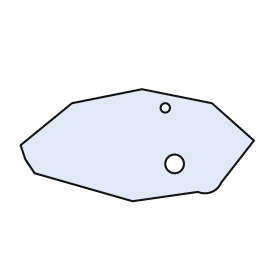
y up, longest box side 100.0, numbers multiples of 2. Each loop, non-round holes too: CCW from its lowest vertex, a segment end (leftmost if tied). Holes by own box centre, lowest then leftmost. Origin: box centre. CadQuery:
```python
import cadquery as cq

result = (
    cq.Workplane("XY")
    .moveTo(-2.0, -24.0)
    .lineTo(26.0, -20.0)
    .threePointArc((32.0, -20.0), (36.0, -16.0))
    .lineTo(50.0, 2.0)
    .lineTo(32.0, 18.0)
    .lineTo(2.0, 24.0)
    .lineTo(-28.0, 18.0)
    .lineTo(-50.0, 0.0)
    .lineTo(-48.0, -6.0)
    .lineTo(-44.0, -12.0)
    .close()
    .moveTo(16.0, -8.0)
    .circle(4.0)
    .moveTo(12.0, 16.0)
    .circle(2.0)
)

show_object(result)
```